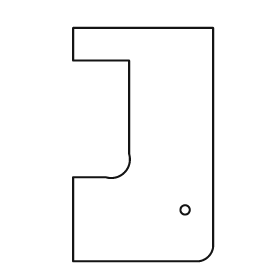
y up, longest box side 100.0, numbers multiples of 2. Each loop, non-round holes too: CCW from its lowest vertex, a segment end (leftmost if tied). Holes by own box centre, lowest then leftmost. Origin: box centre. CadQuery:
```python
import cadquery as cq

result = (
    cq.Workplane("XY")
    .moveTo(-30.0, -50.0)
    .lineTo(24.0, -50.0)
    .threePointArc((28.0, -48.0), (30.0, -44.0))
    .lineTo(30.0, 50.0)
    .lineTo(-30.0, 50.0)
    .lineTo(-30.0, 36.0)
    .lineTo(-6.0, 36.0)
    .lineTo(-6.0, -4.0)
    .threePointArc((-8.0, -12.0), (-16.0, -14.0))
    .lineTo(-30.0, -14.0)
    .close()
    .moveTo(18.0, -28.0)
    .circle(2.0)
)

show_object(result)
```